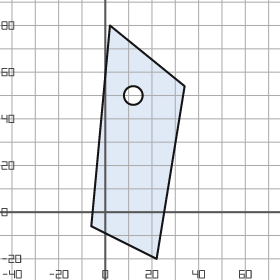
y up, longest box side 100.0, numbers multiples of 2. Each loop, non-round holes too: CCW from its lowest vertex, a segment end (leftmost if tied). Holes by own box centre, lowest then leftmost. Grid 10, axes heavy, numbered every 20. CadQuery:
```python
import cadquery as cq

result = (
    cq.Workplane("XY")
    .moveTo(22.0, -20.0)
    .lineTo(34.0, 54.0)
    .lineTo(2.0, 80.0)
    .lineTo(-6.0, -6.0)
    .close()
    .moveTo(12.0, 50.0)
    .circle(4.0)
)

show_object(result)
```